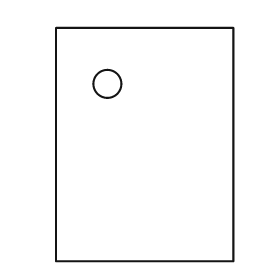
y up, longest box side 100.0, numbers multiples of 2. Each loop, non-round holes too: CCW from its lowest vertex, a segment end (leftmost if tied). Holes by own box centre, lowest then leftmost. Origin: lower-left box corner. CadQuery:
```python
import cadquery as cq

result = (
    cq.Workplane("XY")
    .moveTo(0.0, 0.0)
    .lineTo(76.0, 0.0)
    .lineTo(76.0, 100.0)
    .lineTo(0.0, 100.0)
    .close()
    .moveTo(22.0, 76.0)
    .circle(6.0)
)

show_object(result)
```